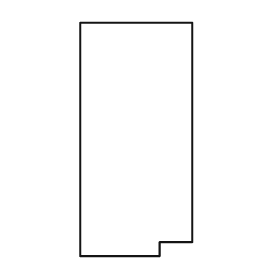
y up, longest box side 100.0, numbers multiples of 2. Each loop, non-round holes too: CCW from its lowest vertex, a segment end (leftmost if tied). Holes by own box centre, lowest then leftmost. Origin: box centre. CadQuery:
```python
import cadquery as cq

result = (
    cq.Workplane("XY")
    .moveTo(-24.0, -50.0)
    .lineTo(10.0, -50.0)
    .lineTo(10.0, -44.0)
    .lineTo(24.0, -44.0)
    .lineTo(24.0, 50.0)
    .lineTo(-24.0, 50.0)
    .close()
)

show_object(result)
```